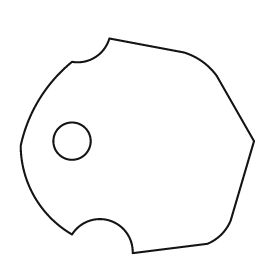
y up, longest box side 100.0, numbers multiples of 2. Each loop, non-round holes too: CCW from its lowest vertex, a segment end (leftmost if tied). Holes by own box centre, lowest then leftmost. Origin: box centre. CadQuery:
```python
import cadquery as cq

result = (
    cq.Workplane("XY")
    .moveTo(-2.0, -46.0)
    .lineTo(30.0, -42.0)
    .threePointArc((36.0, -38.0), (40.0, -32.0))
    .lineTo(50.0, 2.0)
    .lineTo(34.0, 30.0)
    .threePointArc((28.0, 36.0), (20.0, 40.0))
    .lineTo(-12.0, 46.0)
    .threePointArc((-18.0, 38.0), (-28.0, 36.0))
    .threePointArc((-42.0, 20.0), (-50.0, 0.0))
    .threePointArc((-44.0, -22.0), (-28.0, -38.0))
    .threePointArc((-12.0, -32.0), (-2.0, -46.0))
    .close()
    .moveTo(-28.0, 2.0)
    .circle(8.0)
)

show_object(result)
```